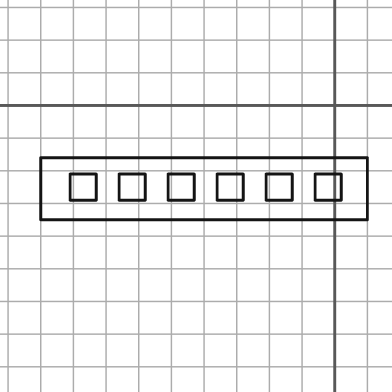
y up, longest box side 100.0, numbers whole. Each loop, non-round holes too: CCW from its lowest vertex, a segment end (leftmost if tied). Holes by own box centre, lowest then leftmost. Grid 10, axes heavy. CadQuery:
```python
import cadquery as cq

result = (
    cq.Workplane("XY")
    .moveTo(-90.0, -35.0)
    .lineTo(10.0, -35.0)
    .lineTo(10.0, -16.0)
    .lineTo(-90.0, -16.0)
    .close()
    .moveTo(-81.0, -29.0)
    .lineTo(-73.0, -29.0)
    .lineTo(-73.0, -21.0)
    .lineTo(-81.0, -21.0)
    .close()
    .moveTo(-66.0, -29.0)
    .lineTo(-58.0, -29.0)
    .lineTo(-58.0, -21.0)
    .lineTo(-66.0, -21.0)
    .close()
    .moveTo(-51.0, -29.0)
    .lineTo(-43.0, -29.0)
    .lineTo(-43.0, -21.0)
    .lineTo(-51.0, -21.0)
    .close()
    .moveTo(-36.0, -29.0)
    .lineTo(-28.0, -29.0)
    .lineTo(-28.0, -21.0)
    .lineTo(-36.0, -21.0)
    .close()
    .moveTo(-21.0, -29.0)
    .lineTo(-13.0, -29.0)
    .lineTo(-13.0, -21.0)
    .lineTo(-21.0, -21.0)
    .close()
    .moveTo(-6.0, -29.0)
    .lineTo(2.0, -29.0)
    .lineTo(2.0, -21.0)
    .lineTo(-6.0, -21.0)
    .close()
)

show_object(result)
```